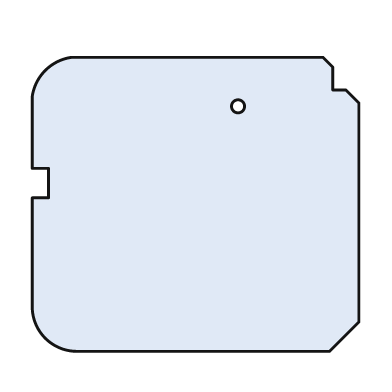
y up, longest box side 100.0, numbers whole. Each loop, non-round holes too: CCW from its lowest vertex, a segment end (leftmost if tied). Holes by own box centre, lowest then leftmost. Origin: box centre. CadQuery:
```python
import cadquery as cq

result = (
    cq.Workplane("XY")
    .moveTo(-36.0, -45.0)
    .lineTo(41.0, -45.0)
    .lineTo(50.0, -36.0)
    .lineTo(50.0, 31.0)
    .lineTo(46.0, 35.0)
    .lineTo(42.0, 35.0)
    .lineTo(42.0, 42.0)
    .lineTo(39.0, 45.0)
    .lineTo(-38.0, 45.0)
    .threePointArc((-46.0, 41.0), (-50.0, 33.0))
    .lineTo(-50.0, 11.0)
    .lineTo(-45.0, 11.0)
    .lineTo(-45.0, 2.0)
    .lineTo(-50.0, 2.0)
    .lineTo(-50.0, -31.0)
    .threePointArc((-46.0, -41.0), (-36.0, -45.0))
    .close()
    .moveTo(13.0, 30.0)
    .circle(2.0)
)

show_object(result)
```